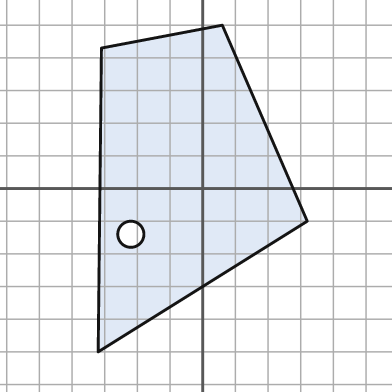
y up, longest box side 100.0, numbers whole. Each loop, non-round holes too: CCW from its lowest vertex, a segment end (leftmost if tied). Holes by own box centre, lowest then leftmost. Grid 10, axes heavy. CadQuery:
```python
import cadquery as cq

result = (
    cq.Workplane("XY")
    .moveTo(-32.0, -50.0)
    .lineTo(32.0, -10.0)
    .lineTo(6.0, 50.0)
    .lineTo(-31.0, 43.0)
    .close()
    .moveTo(-22.0, -14.0)
    .circle(4.0)
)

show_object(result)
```